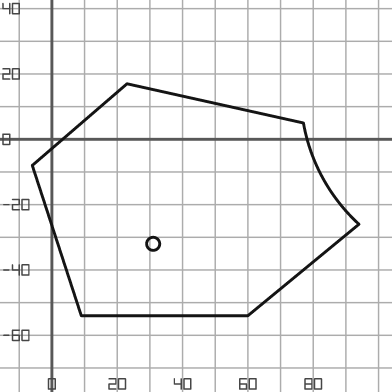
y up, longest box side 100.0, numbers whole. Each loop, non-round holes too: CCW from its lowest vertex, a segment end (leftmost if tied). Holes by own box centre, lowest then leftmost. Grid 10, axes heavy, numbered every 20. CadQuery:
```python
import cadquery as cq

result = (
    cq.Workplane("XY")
    .moveTo(9.0, -54.0)
    .lineTo(60.0, -54.0)
    .lineTo(94.0, -26.0)
    .threePointArc((83.0, -12.0), (77.0, 5.0))
    .lineTo(23.0, 17.0)
    .lineTo(-6.0, -8.0)
    .close()
    .moveTo(31.0, -32.0)
    .circle(2.0)
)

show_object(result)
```